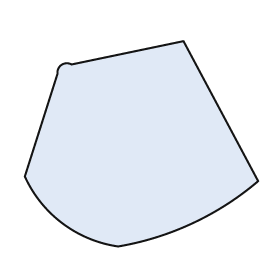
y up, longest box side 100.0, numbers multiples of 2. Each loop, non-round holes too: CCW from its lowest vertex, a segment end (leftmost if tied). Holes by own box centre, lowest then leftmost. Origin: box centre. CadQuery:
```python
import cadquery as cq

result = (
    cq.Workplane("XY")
    .moveTo(-10.0, -44.0)
    .threePointArc((22.0, -34.0), (50.0, -16.0))
    .lineTo(18.0, 44.0)
    .lineTo(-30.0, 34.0)
    .threePointArc((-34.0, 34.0), (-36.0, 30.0))
    .lineTo(-50.0, -14.0)
    .threePointArc((-34.0, -34.0), (-10.0, -44.0))
    .close()
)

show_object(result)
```